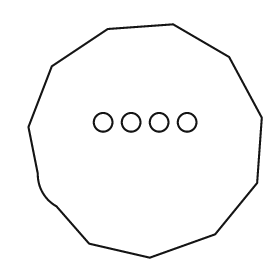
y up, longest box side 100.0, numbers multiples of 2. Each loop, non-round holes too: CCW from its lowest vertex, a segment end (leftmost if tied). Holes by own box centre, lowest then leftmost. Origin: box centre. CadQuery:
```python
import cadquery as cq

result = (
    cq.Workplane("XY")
    .moveTo(2.0, -50.0)
    .lineTo(30.0, -40.0)
    .lineTo(48.0, -18.0)
    .lineTo(50.0, 10.0)
    .lineTo(36.0, 36.0)
    .lineTo(12.0, 50.0)
    .lineTo(-16.0, 48.0)
    .lineTo(-40.0, 32.0)
    .lineTo(-50.0, 6.0)
    .lineTo(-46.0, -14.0)
    .threePointArc((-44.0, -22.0), (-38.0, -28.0))
    .lineTo(-24.0, -44.0)
    .close()
    .moveTo(-18.0, 8.0)
    .circle(4.0)
    .moveTo(-6.0, 8.0)
    .circle(4.0)
    .moveTo(6.0, 8.0)
    .circle(4.0)
    .moveTo(18.0, 8.0)
    .circle(4.0)
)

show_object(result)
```